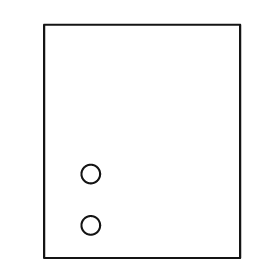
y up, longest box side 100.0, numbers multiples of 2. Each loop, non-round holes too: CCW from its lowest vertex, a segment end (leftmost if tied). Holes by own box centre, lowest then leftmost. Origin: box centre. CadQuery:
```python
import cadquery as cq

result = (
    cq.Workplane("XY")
    .moveTo(-42.0, -50.0)
    .lineTo(42.0, -50.0)
    .lineTo(42.0, 50.0)
    .lineTo(-42.0, 50.0)
    .close()
    .moveTo(-22.0, -36.0)
    .circle(4.0)
    .moveTo(-22.0, -14.0)
    .circle(4.0)
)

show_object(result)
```